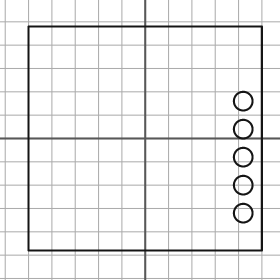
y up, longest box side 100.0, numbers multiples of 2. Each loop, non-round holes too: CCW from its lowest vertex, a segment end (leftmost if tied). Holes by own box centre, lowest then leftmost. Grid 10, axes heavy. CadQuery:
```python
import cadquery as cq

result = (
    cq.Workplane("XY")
    .moveTo(-50.0, -48.0)
    .lineTo(50.0, -48.0)
    .lineTo(50.0, 48.0)
    .lineTo(-50.0, 48.0)
    .close()
    .moveTo(42.0, -32.0)
    .circle(4.0)
    .moveTo(42.0, -20.0)
    .circle(4.0)
    .moveTo(42.0, -8.0)
    .circle(4.0)
    .moveTo(42.0, 4.0)
    .circle(4.0)
    .moveTo(42.0, 16.0)
    .circle(4.0)
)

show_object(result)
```